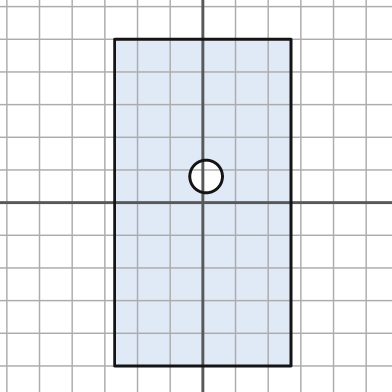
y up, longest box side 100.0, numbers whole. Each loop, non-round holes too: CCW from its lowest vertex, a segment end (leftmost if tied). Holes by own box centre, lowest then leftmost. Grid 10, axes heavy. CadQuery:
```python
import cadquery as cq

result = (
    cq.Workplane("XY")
    .moveTo(-27.0, -50.0)
    .lineTo(27.0, -50.0)
    .lineTo(27.0, 50.0)
    .lineTo(-27.0, 50.0)
    .close()
    .moveTo(1.0, 8.0)
    .circle(5.0)
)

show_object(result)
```